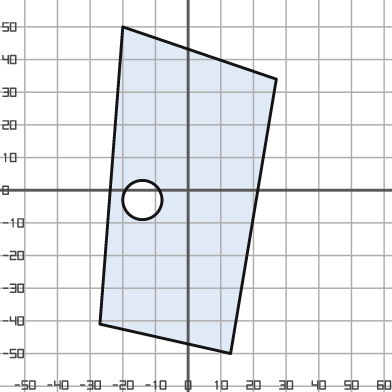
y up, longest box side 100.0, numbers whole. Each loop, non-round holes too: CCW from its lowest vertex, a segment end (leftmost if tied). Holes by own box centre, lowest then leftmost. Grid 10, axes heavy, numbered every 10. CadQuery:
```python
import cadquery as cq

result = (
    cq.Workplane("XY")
    .moveTo(13.0, -50.0)
    .lineTo(27.0, 34.0)
    .lineTo(-20.0, 50.0)
    .lineTo(-27.0, -41.0)
    .close()
    .moveTo(-14.0, -3.0)
    .circle(6.0)
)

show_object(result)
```